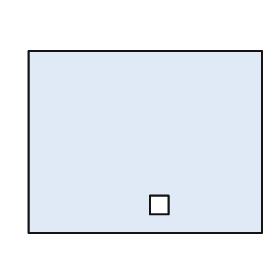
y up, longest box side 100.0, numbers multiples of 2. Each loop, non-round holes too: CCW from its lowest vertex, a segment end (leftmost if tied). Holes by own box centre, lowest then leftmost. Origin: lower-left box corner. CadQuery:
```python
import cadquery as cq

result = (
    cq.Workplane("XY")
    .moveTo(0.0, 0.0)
    .lineTo(100.0, 0.0)
    .lineTo(100.0, 78.0)
    .lineTo(0.0, 78.0)
    .close()
    .moveTo(52.0, 8.0)
    .lineTo(60.0, 8.0)
    .lineTo(60.0, 16.0)
    .lineTo(52.0, 16.0)
    .close()
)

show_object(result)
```